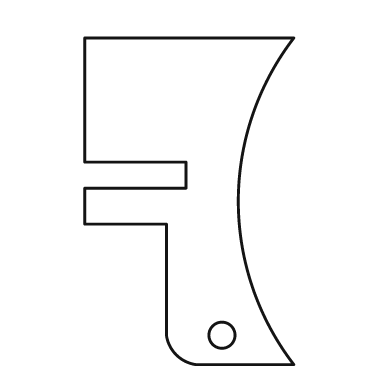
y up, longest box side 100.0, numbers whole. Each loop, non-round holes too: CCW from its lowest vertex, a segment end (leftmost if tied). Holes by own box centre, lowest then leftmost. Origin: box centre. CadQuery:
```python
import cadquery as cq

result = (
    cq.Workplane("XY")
    .moveTo(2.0, -50.0)
    .lineTo(32.0, -50.0)
    .threePointArc((15.0, 0.0), (32.0, 50.0))
    .lineTo(-32.0, 50.0)
    .lineTo(-32.0, 12.0)
    .lineTo(-1.0, 12.0)
    .lineTo(-1.0, 4.0)
    .lineTo(-32.0, 4.0)
    .lineTo(-32.0, -7.0)
    .lineTo(-7.0, -7.0)
    .lineTo(-7.0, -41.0)
    .threePointArc((-4.0, -47.0), (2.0, -50.0))
    .close()
    .moveTo(10.0, -41.0)
    .circle(4.0)
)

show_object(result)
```